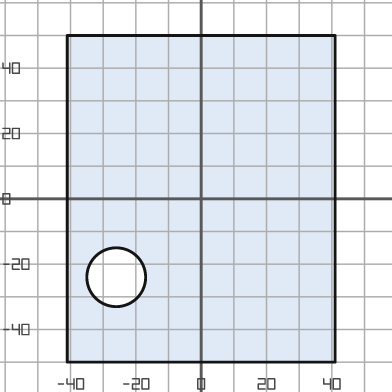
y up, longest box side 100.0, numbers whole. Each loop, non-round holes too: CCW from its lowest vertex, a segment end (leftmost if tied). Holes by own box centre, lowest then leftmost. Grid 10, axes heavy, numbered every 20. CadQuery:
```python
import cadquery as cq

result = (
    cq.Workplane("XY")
    .moveTo(-41.0, -50.0)
    .lineTo(41.0, -50.0)
    .lineTo(41.0, 50.0)
    .lineTo(-41.0, 50.0)
    .close()
    .moveTo(-26.0, -24.0)
    .circle(9.0)
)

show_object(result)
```